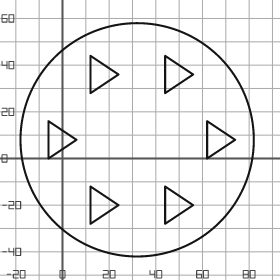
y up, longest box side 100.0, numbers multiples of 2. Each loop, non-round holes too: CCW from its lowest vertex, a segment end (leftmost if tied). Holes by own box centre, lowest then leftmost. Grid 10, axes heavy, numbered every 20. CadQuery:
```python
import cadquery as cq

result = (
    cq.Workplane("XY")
    .moveTo(32.0, 8.0)
    .circle(50.0)
    .moveTo(12.0, -28.0)
    .lineTo(24.0, -20.0)
    .lineTo(12.0, -12.0)
    .close()
    .moveTo(44.0, -28.0)
    .lineTo(56.0, -20.0)
    .lineTo(44.0, -12.0)
    .close()
    .moveTo(-6.0, 0.0)
    .lineTo(6.0, 8.0)
    .lineTo(-6.0, 16.0)
    .close()
    .moveTo(62.0, 0.0)
    .lineTo(74.0, 8.0)
    .lineTo(62.0, 16.0)
    .close()
    .moveTo(12.0, 28.0)
    .lineTo(24.0, 36.0)
    .lineTo(12.0, 44.0)
    .close()
    .moveTo(44.0, 28.0)
    .lineTo(56.0, 36.0)
    .lineTo(44.0, 44.0)
    .close()
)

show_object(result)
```